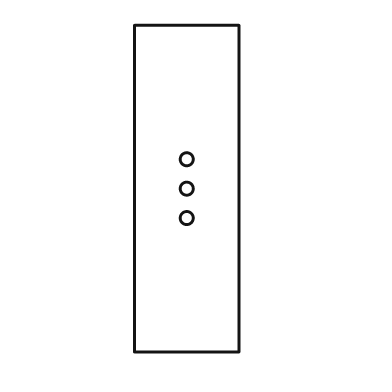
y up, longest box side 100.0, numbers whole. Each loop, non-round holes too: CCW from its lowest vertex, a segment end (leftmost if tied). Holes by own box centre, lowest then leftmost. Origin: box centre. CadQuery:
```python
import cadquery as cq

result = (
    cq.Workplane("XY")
    .moveTo(-16.0, -50.0)
    .lineTo(16.0, -50.0)
    .lineTo(16.0, 50.0)
    .lineTo(-16.0, 50.0)
    .close()
    .moveTo(0.0, -9.0)
    .circle(2.0)
    .moveTo(0.0, 0.0)
    .circle(2.0)
    .moveTo(0.0, 9.0)
    .circle(2.0)
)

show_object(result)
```